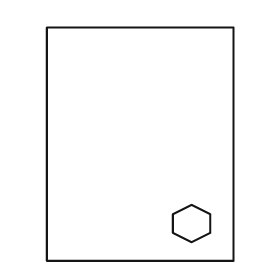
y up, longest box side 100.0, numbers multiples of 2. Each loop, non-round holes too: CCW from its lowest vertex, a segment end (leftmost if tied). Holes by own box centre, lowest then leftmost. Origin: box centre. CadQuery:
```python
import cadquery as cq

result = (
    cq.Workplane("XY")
    .moveTo(-40.0, -50.0)
    .lineTo(40.0, -50.0)
    .lineTo(40.0, 50.0)
    .lineTo(-40.0, 50.0)
    .close()
    .moveTo(22.0, -42.0)
    .lineTo(30.0, -38.0)
    .lineTo(30.0, -30.0)
    .lineTo(22.0, -26.0)
    .lineTo(14.0, -30.0)
    .lineTo(14.0, -38.0)
    .close()
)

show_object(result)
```